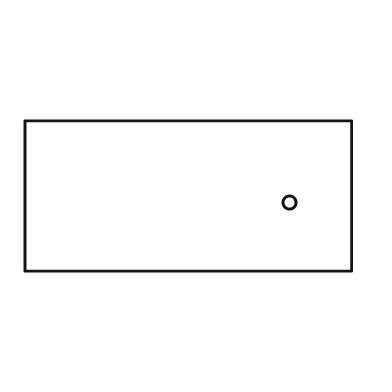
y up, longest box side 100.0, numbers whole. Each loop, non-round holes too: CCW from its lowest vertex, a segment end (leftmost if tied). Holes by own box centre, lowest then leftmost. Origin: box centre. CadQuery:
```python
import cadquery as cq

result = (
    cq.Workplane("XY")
    .moveTo(-50.0, -23.0)
    .lineTo(50.0, -23.0)
    .lineTo(50.0, 23.0)
    .lineTo(-50.0, 23.0)
    .close()
    .moveTo(31.0, -2.0)
    .circle(2.0)
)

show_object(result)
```